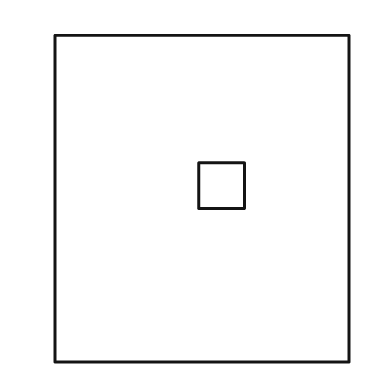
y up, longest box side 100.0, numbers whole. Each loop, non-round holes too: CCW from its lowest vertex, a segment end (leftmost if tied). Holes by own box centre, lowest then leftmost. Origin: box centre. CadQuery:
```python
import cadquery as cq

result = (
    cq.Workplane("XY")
    .moveTo(-45.0, -50.0)
    .lineTo(45.0, -50.0)
    .lineTo(45.0, 50.0)
    .lineTo(-45.0, 50.0)
    .close()
    .moveTo(-1.0, -3.0)
    .lineTo(13.0, -3.0)
    .lineTo(13.0, 11.0)
    .lineTo(-1.0, 11.0)
    .close()
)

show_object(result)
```